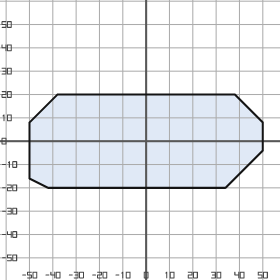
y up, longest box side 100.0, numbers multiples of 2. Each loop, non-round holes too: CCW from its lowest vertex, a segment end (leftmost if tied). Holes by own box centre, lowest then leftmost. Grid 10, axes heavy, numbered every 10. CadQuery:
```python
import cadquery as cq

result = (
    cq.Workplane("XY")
    .moveTo(-42.0, -20.0)
    .lineTo(34.0, -20.0)
    .lineTo(50.0, -4.0)
    .lineTo(50.0, 8.0)
    .lineTo(38.0, 20.0)
    .lineTo(-38.0, 20.0)
    .lineTo(-50.0, 8.0)
    .lineTo(-50.0, -16.0)
    .close()
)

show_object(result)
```